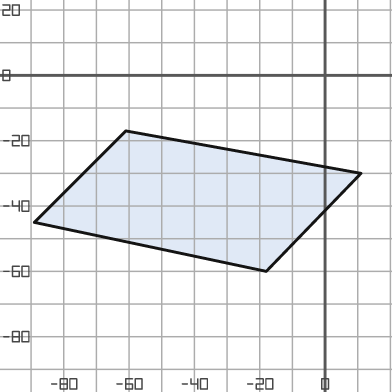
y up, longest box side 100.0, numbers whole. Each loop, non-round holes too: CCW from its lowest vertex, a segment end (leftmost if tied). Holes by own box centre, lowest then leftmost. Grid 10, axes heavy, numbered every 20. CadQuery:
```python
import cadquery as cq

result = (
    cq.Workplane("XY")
    .moveTo(-18.0, -60.0)
    .lineTo(11.0, -30.0)
    .lineTo(-61.0, -17.0)
    .lineTo(-89.0, -45.0)
    .close()
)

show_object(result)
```